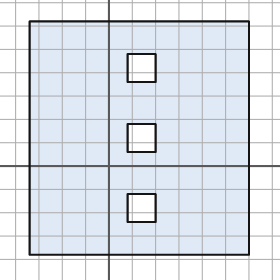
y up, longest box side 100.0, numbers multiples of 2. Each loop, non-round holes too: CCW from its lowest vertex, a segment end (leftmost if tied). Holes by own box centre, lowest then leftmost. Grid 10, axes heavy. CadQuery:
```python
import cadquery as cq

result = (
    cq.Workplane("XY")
    .moveTo(-34.0, -38.0)
    .lineTo(60.0, -38.0)
    .lineTo(60.0, 62.0)
    .lineTo(-34.0, 62.0)
    .close()
    .moveTo(8.0, -24.0)
    .lineTo(20.0, -24.0)
    .lineTo(20.0, -12.0)
    .lineTo(8.0, -12.0)
    .close()
    .moveTo(8.0, 6.0)
    .lineTo(20.0, 6.0)
    .lineTo(20.0, 18.0)
    .lineTo(8.0, 18.0)
    .close()
    .moveTo(8.0, 36.0)
    .lineTo(20.0, 36.0)
    .lineTo(20.0, 48.0)
    .lineTo(8.0, 48.0)
    .close()
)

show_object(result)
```